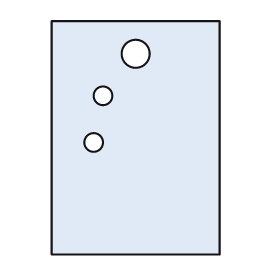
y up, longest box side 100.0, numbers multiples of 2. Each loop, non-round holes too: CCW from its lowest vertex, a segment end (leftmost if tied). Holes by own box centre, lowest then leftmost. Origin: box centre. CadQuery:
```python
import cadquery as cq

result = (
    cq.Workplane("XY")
    .moveTo(-36.0, -50.0)
    .lineTo(36.0, -50.0)
    .lineTo(36.0, 50.0)
    .lineTo(-36.0, 50.0)
    .close()
    .moveTo(-18.0, -2.0)
    .circle(4.0)
    .moveTo(-14.0, 18.0)
    .circle(4.0)
    .moveTo(0.0, 36.0)
    .circle(6.0)
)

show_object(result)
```